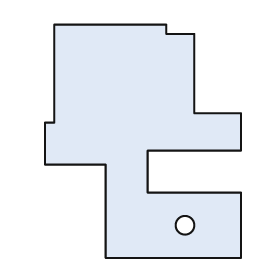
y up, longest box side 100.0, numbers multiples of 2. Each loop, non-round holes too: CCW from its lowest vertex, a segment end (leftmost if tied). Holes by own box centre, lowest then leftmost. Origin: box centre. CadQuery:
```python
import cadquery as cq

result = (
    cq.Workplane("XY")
    .moveTo(-16.0, -50.0)
    .lineTo(42.0, -50.0)
    .lineTo(42.0, -22.0)
    .lineTo(2.0, -22.0)
    .lineTo(2.0, -4.0)
    .lineTo(42.0, -4.0)
    .lineTo(42.0, 12.0)
    .lineTo(22.0, 12.0)
    .lineTo(22.0, 46.0)
    .lineTo(10.0, 46.0)
    .lineTo(10.0, 50.0)
    .lineTo(-38.0, 50.0)
    .lineTo(-38.0, 8.0)
    .lineTo(-42.0, 8.0)
    .lineTo(-42.0, -10.0)
    .lineTo(-16.0, -10.0)
    .close()
    .moveTo(18.0, -36.0)
    .circle(4.0)
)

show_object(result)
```